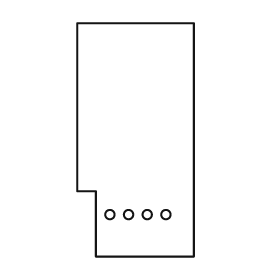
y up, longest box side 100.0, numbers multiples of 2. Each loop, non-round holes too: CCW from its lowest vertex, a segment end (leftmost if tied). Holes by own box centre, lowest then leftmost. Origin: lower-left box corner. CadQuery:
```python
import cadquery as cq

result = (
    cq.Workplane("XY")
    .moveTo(8.0, 0.0)
    .lineTo(50.0, 0.0)
    .lineTo(50.0, 100.0)
    .lineTo(0.0, 100.0)
    .lineTo(0.0, 28.0)
    .lineTo(8.0, 28.0)
    .close()
    .moveTo(14.0, 18.0)
    .circle(2.0)
    .moveTo(22.0, 18.0)
    .circle(2.0)
    .moveTo(30.0, 18.0)
    .circle(2.0)
    .moveTo(38.0, 18.0)
    .circle(2.0)
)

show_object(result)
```